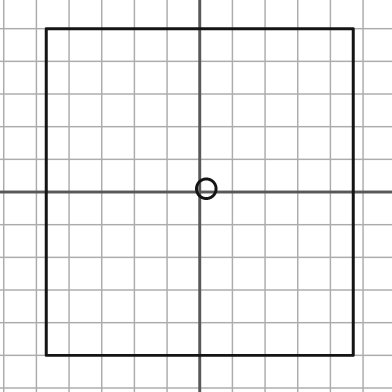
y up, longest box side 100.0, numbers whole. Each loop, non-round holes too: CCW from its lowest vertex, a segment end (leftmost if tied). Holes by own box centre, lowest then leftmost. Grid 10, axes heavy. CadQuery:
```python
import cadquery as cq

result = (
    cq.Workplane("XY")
    .moveTo(-47.0, -50.0)
    .lineTo(47.0, -50.0)
    .lineTo(47.0, 50.0)
    .lineTo(-47.0, 50.0)
    .close()
    .moveTo(2.0, 1.0)
    .circle(3.0)
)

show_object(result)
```